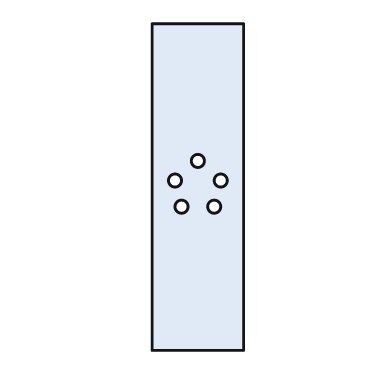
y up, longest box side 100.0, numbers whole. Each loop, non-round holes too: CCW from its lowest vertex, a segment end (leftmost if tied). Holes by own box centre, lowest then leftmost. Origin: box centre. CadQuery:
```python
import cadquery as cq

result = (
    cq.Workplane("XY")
    .moveTo(-14.0, -50.0)
    .lineTo(14.0, -50.0)
    .lineTo(14.0, 50.0)
    .lineTo(-14.0, 50.0)
    .close()
    .moveTo(-5.0, -6.0)
    .circle(2.0)
    .moveTo(5.0, -6.0)
    .circle(2.0)
    .moveTo(-7.0, 2.0)
    .circle(2.0)
    .moveTo(7.0, 2.0)
    .circle(2.0)
    .moveTo(0.0, 8.0)
    .circle(2.0)
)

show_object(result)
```